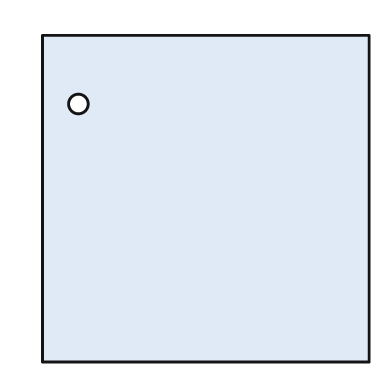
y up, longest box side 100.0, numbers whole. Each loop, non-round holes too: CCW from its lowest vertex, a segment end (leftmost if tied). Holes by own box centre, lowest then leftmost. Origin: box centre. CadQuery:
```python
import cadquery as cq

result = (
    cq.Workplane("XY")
    .moveTo(-50.0, -50.0)
    .lineTo(50.0, -50.0)
    .lineTo(50.0, 50.0)
    .lineTo(-50.0, 50.0)
    .close()
    .moveTo(-39.0, 29.0)
    .circle(3.0)
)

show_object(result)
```